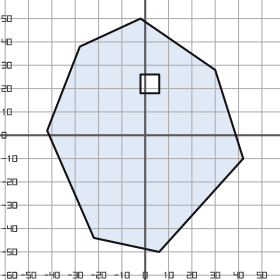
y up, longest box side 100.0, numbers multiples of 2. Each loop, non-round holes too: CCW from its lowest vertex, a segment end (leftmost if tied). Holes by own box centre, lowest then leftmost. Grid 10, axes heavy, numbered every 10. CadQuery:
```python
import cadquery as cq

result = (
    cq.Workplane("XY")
    .moveTo(6.0, -50.0)
    .lineTo(42.0, -10.0)
    .lineTo(30.0, 28.0)
    .lineTo(-2.0, 50.0)
    .lineTo(-28.0, 38.0)
    .lineTo(-42.0, 2.0)
    .lineTo(-22.0, -44.0)
    .close()
    .moveTo(-2.0, 18.0)
    .lineTo(6.0, 18.0)
    .lineTo(6.0, 26.0)
    .lineTo(-2.0, 26.0)
    .close()
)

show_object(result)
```